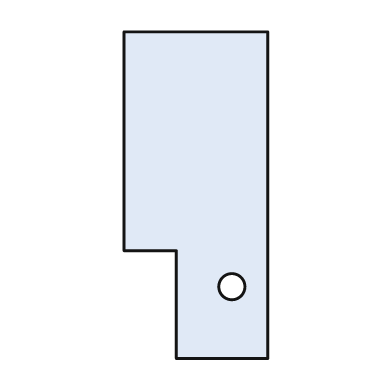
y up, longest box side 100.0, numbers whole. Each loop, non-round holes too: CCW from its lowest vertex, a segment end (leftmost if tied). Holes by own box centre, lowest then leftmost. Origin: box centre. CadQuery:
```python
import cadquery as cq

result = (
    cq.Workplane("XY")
    .moveTo(-6.0, -50.0)
    .lineTo(22.0, -50.0)
    .lineTo(22.0, 50.0)
    .lineTo(-22.0, 50.0)
    .lineTo(-22.0, -17.0)
    .lineTo(-6.0, -17.0)
    .close()
    .moveTo(11.0, -28.0)
    .circle(4.0)
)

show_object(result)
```